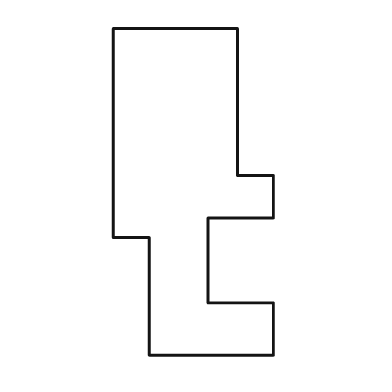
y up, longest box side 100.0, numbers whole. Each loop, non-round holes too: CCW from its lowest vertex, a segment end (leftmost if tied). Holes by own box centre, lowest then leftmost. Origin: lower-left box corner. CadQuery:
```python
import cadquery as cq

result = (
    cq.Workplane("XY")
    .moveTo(11.0, 0.0)
    .lineTo(49.0, 0.0)
    .lineTo(49.0, 16.0)
    .lineTo(29.0, 16.0)
    .lineTo(29.0, 42.0)
    .lineTo(49.0, 42.0)
    .lineTo(49.0, 55.0)
    .lineTo(38.0, 55.0)
    .lineTo(38.0, 100.0)
    .lineTo(0.0, 100.0)
    .lineTo(0.0, 36.0)
    .lineTo(11.0, 36.0)
    .close()
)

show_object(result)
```